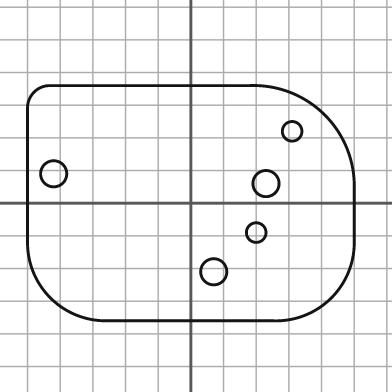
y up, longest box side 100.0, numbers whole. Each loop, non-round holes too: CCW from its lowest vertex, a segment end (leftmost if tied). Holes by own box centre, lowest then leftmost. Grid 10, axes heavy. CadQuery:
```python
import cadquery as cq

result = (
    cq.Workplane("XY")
    .moveTo(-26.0, -36.0)
    .lineTo(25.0, -36.0)
    .threePointArc((43.0, -29.0), (50.0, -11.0))
    .lineTo(50.0, 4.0)
    .threePointArc((41.0, 27.0), (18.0, 36.0))
    .lineTo(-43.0, 36.0)
    .threePointArc((-48.0, 34.0), (-50.0, 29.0))
    .lineTo(-50.0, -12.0)
    .threePointArc((-43.0, -29.0), (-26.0, -36.0))
    .close()
    .moveTo(7.0, -21.0)
    .circle(4.0)
    .moveTo(20.0, -9.0)
    .circle(3.0)
    .moveTo(23.0, 6.0)
    .circle(4.0)
    .moveTo(-42.0, 9.0)
    .circle(4.0)
    .moveTo(31.0, 22.0)
    .circle(3.0)
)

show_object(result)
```